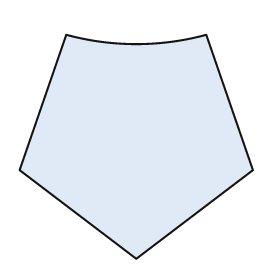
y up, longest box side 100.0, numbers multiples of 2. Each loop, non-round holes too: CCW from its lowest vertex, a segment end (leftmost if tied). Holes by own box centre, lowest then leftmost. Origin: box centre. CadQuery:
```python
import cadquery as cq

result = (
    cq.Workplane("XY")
    .moveTo(0.0, -48.0)
    .lineTo(50.0, -10.0)
    .lineTo(30.0, 48.0)
    .threePointArc((0.0, 44.0), (-30.0, 48.0))
    .lineTo(-50.0, -10.0)
    .close()
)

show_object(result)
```